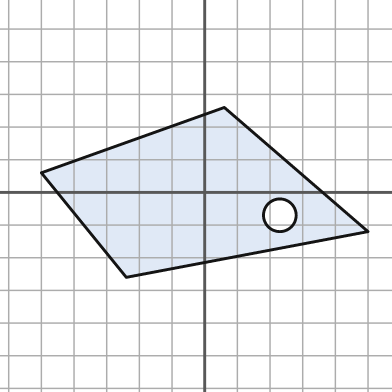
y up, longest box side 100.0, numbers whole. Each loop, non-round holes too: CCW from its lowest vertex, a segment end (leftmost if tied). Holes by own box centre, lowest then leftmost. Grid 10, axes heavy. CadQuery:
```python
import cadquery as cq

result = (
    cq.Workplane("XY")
    .moveTo(-24.0, -26.0)
    .lineTo(50.0, -12.0)
    .lineTo(6.0, 26.0)
    .lineTo(-50.0, 6.0)
    .close()
    .moveTo(23.0, -7.0)
    .circle(5.0)
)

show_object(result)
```